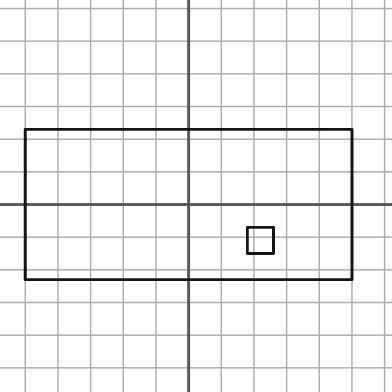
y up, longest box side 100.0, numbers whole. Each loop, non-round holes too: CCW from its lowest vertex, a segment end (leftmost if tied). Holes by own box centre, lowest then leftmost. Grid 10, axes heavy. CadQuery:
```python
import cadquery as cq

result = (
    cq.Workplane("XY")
    .moveTo(-50.0, -23.0)
    .lineTo(50.0, -23.0)
    .lineTo(50.0, 23.0)
    .lineTo(-50.0, 23.0)
    .close()
    .moveTo(18.0, -15.0)
    .lineTo(26.0, -15.0)
    .lineTo(26.0, -7.0)
    .lineTo(18.0, -7.0)
    .close()
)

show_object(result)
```